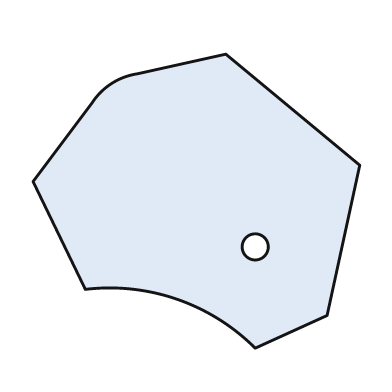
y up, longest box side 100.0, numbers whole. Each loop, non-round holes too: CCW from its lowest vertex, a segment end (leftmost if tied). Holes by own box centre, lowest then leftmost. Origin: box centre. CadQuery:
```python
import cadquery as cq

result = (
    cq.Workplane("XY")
    .moveTo(18.0, -45.0)
    .lineTo(40.0, -35.0)
    .lineTo(50.0, 11.0)
    .lineTo(9.0, 45.0)
    .lineTo(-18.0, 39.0)
    .threePointArc((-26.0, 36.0), (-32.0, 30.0))
    .lineTo(-50.0, 6.0)
    .lineTo(-34.0, -27.0)
    .threePointArc((-6.0, -30.0), (18.0, -45.0))
    .close()
    .moveTo(18.0, -14.0)
    .circle(4.0)
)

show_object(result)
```